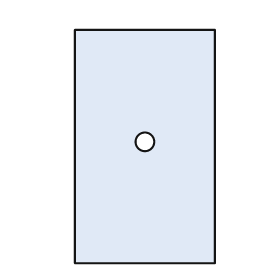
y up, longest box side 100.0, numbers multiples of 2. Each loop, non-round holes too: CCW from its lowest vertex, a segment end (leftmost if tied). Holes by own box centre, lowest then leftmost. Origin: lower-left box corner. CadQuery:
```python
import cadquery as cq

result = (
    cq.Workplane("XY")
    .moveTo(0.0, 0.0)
    .lineTo(60.0, 0.0)
    .lineTo(60.0, 100.0)
    .lineTo(0.0, 100.0)
    .close()
    .moveTo(30.0, 52.0)
    .circle(4.0)
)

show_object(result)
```